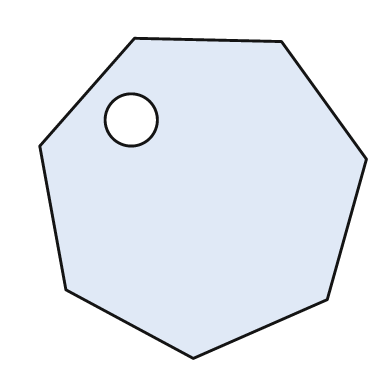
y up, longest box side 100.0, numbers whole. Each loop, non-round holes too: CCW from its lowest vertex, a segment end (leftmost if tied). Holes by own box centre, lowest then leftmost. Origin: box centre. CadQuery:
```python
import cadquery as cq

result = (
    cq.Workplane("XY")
    .moveTo(-3.0, -49.0)
    .lineTo(38.0, -31.0)
    .lineTo(50.0, 12.0)
    .lineTo(24.0, 48.0)
    .lineTo(-21.0, 49.0)
    .lineTo(-50.0, 16.0)
    .lineTo(-42.0, -28.0)
    .close()
    .moveTo(-22.0, 24.0)
    .circle(8.0)
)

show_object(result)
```